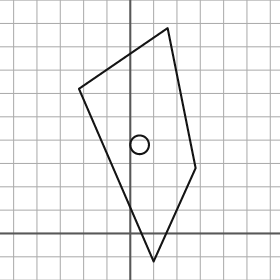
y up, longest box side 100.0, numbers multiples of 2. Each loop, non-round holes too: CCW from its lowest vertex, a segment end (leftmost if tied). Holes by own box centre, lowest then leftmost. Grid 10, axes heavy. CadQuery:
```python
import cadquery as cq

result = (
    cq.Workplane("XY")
    .moveTo(10.0, -12.0)
    .lineTo(28.0, 28.0)
    .lineTo(16.0, 88.0)
    .lineTo(-22.0, 62.0)
    .close()
    .moveTo(4.0, 38.0)
    .circle(4.0)
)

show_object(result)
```